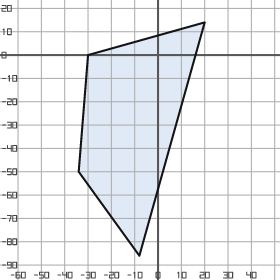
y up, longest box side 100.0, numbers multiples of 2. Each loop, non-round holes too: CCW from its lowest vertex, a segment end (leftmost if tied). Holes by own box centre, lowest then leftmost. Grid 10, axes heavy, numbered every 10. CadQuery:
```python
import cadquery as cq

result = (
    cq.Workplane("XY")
    .moveTo(-8.0, -86.0)
    .lineTo(20.0, 14.0)
    .lineTo(-30.0, 0.0)
    .lineTo(-34.0, -50.0)
    .close()
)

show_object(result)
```